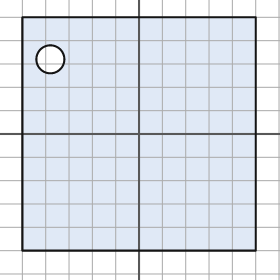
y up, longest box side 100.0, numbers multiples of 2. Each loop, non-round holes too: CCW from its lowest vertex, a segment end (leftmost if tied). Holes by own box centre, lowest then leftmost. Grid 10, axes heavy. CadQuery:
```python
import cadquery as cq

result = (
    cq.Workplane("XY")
    .moveTo(-50.0, -50.0)
    .lineTo(50.0, -50.0)
    .lineTo(50.0, 50.0)
    .lineTo(-50.0, 50.0)
    .close()
    .moveTo(-38.0, 32.0)
    .circle(6.0)
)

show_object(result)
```